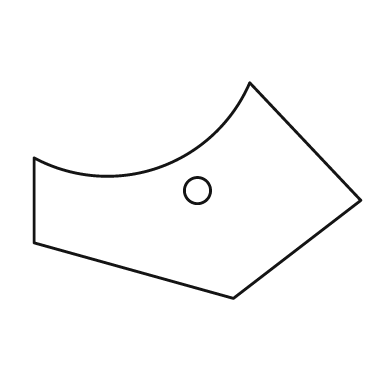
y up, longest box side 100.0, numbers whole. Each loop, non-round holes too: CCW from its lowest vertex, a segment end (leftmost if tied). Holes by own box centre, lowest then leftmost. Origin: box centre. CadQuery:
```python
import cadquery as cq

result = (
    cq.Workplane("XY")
    .moveTo(11.0, -33.0)
    .lineTo(50.0, -3.0)
    .lineTo(16.0, 33.0)
    .threePointArc((-12.0, 7.0), (-50.0, 10.0))
    .lineTo(-50.0, -16.0)
    .close()
    .moveTo(0.0, 0.0)
    .circle(4.0)
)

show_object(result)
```